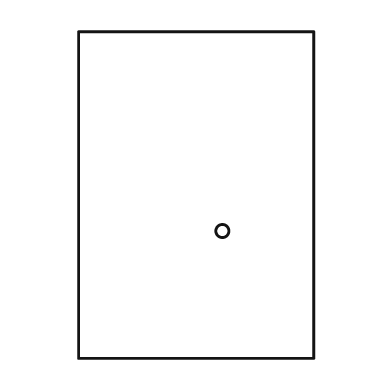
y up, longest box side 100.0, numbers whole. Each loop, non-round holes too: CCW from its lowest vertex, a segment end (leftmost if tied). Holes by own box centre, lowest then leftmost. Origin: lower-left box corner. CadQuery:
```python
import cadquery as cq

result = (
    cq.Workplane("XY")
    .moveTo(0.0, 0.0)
    .lineTo(72.0, 0.0)
    .lineTo(72.0, 100.0)
    .lineTo(0.0, 100.0)
    .close()
    .moveTo(44.0, 39.0)
    .circle(2.0)
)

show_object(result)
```